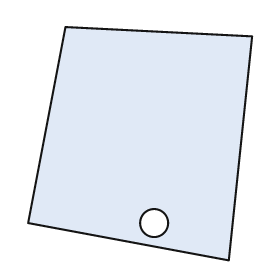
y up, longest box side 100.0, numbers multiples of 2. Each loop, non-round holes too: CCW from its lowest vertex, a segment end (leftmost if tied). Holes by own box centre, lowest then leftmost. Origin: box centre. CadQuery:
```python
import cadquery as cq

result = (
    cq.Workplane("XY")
    .moveTo(38.0, -50.0)
    .lineTo(48.0, 46.0)
    .lineTo(-32.0, 50.0)
    .lineTo(-48.0, -34.0)
    .close()
    .moveTo(6.0, -34.0)
    .circle(6.0)
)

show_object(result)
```